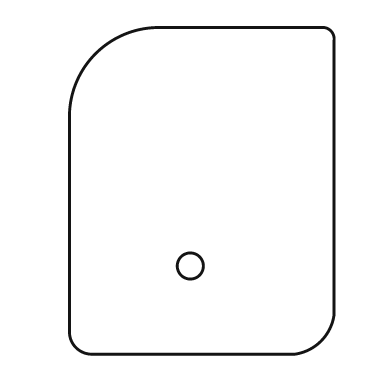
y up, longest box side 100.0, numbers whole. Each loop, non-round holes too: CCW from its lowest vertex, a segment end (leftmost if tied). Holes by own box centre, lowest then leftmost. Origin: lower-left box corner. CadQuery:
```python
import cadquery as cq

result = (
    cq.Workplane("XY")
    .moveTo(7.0, 0.0)
    .lineTo(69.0, 0.0)
    .threePointArc((77.0, 4.0), (81.0, 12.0))
    .lineTo(81.0, 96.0)
    .threePointArc((80.0, 99.0), (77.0, 100.0))
    .lineTo(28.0, 100.0)
    .threePointArc((8.0, 92.0), (0.0, 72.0))
    .lineTo(0.0, 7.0)
    .threePointArc((2.0, 2.0), (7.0, 0.0))
    .close()
    .moveTo(37.0, 27.0)
    .circle(4.0)
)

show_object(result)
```